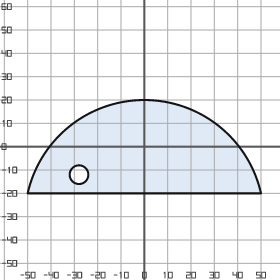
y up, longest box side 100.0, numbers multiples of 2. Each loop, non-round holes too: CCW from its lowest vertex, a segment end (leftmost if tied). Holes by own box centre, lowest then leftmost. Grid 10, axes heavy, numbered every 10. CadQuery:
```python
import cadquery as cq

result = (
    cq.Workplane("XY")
    .moveTo(-50.0, -20.0)
    .lineTo(50.0, -20.0)
    .threePointArc((0.0, 20.0), (-50.0, -20.0))
    .close()
    .moveTo(-28.0, -12.0)
    .circle(4.0)
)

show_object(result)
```